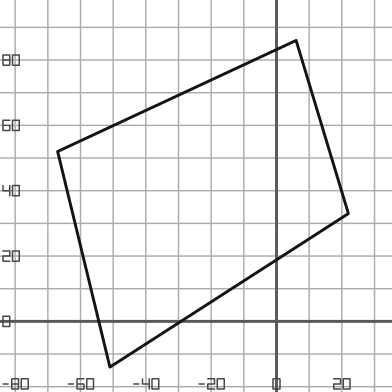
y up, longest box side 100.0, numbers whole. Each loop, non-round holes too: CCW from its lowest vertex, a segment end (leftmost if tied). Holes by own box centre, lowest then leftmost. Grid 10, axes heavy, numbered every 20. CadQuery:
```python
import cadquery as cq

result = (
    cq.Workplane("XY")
    .moveTo(-51.0, -14.0)
    .lineTo(22.0, 33.0)
    .lineTo(6.0, 86.0)
    .lineTo(-67.0, 52.0)
    .close()
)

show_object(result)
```